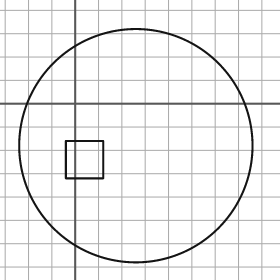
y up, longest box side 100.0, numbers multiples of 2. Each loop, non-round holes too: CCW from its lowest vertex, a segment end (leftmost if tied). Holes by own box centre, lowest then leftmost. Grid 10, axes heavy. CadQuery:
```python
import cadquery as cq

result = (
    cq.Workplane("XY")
    .moveTo(26.0, -18.0)
    .circle(50.0)
    .moveTo(-4.0, -32.0)
    .lineTo(12.0, -32.0)
    .lineTo(12.0, -16.0)
    .lineTo(-4.0, -16.0)
    .close()
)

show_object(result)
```